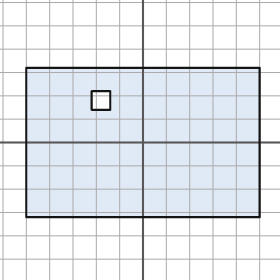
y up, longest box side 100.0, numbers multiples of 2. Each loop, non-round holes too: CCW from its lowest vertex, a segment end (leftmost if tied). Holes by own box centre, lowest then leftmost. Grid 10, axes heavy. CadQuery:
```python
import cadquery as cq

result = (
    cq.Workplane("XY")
    .moveTo(-50.0, -32.0)
    .lineTo(50.0, -32.0)
    .lineTo(50.0, 32.0)
    .lineTo(-50.0, 32.0)
    .close()
    .moveTo(-22.0, 14.0)
    .lineTo(-14.0, 14.0)
    .lineTo(-14.0, 22.0)
    .lineTo(-22.0, 22.0)
    .close()
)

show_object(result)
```